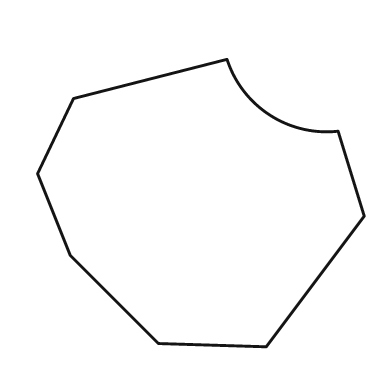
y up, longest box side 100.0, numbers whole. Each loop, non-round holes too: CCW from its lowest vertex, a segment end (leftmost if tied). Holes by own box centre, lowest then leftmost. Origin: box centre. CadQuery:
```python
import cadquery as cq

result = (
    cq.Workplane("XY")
    .moveTo(20.0, -44.0)
    .lineTo(50.0, -4.0)
    .lineTo(42.0, 22.0)
    .threePointArc((21.0, 27.0), (8.0, 44.0))
    .lineTo(-39.0, 32.0)
    .lineTo(-50.0, 9.0)
    .lineTo(-40.0, -16.0)
    .lineTo(-13.0, -43.0)
    .close()
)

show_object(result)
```